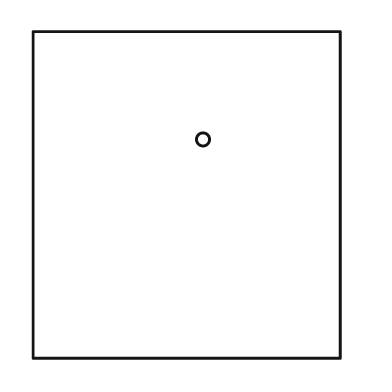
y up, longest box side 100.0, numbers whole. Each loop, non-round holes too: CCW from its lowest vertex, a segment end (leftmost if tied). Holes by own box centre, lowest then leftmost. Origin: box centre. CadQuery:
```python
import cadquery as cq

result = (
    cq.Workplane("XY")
    .moveTo(-47.0, -50.0)
    .lineTo(47.0, -50.0)
    .lineTo(47.0, 50.0)
    .lineTo(-47.0, 50.0)
    .close()
    .moveTo(5.0, 17.0)
    .circle(2.0)
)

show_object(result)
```